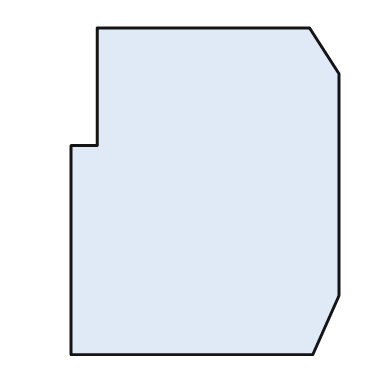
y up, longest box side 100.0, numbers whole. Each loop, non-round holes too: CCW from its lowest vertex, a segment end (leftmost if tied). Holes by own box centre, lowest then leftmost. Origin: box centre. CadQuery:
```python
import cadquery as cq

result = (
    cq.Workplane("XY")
    .moveTo(-41.0, -50.0)
    .lineTo(33.0, -50.0)
    .lineTo(41.0, -32.0)
    .lineTo(41.0, 36.0)
    .lineTo(32.0, 50.0)
    .lineTo(-33.0, 50.0)
    .lineTo(-33.0, 14.0)
    .lineTo(-41.0, 14.0)
    .close()
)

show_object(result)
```